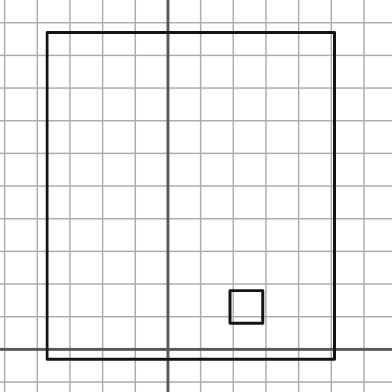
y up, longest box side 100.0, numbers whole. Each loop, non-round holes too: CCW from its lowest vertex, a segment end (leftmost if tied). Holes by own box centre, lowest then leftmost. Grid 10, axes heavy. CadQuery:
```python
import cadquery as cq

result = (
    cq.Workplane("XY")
    .moveTo(-37.0, -3.0)
    .lineTo(51.0, -3.0)
    .lineTo(51.0, 97.0)
    .lineTo(-37.0, 97.0)
    .close()
    .moveTo(19.0, 8.0)
    .lineTo(29.0, 8.0)
    .lineTo(29.0, 18.0)
    .lineTo(19.0, 18.0)
    .close()
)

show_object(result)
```